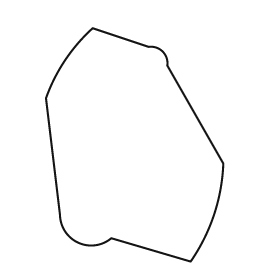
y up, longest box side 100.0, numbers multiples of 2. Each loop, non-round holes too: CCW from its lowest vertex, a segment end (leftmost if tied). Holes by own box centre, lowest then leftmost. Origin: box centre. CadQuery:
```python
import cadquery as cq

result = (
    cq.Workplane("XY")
    .moveTo(24.0, -50.0)
    .threePointArc((34.0, -30.0), (38.0, -8.0))
    .lineTo(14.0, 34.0)
    .threePointArc((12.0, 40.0), (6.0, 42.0))
    .lineTo(-18.0, 50.0)
    .threePointArc((-30.0, 36.0), (-38.0, 20.0))
    .lineTo(-32.0, -30.0)
    .threePointArc((-24.0, -42.0), (-10.0, -40.0))
    .close()
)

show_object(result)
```